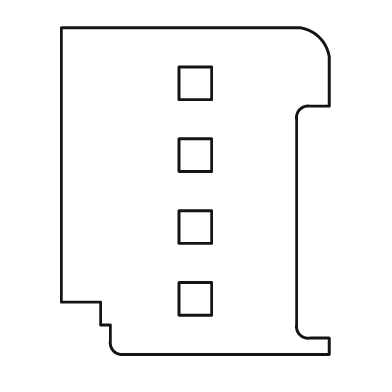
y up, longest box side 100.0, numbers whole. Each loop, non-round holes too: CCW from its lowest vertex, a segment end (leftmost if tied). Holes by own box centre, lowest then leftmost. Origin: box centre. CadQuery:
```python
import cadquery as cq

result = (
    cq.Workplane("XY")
    .moveTo(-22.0, -50.0)
    .lineTo(41.0, -50.0)
    .lineTo(41.0, -45.0)
    .lineTo(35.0, -45.0)
    .threePointArc((32.0, -44.0), (31.0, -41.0))
    .lineTo(31.0, 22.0)
    .threePointArc((32.0, 25.0), (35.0, 26.0))
    .lineTo(41.0, 26.0)
    .lineTo(41.0, 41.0)
    .threePointArc((38.0, 47.0), (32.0, 50.0))
    .lineTo(-41.0, 50.0)
    .lineTo(-41.0, -34.0)
    .lineTo(-29.0, -34.0)
    .lineTo(-29.0, -41.0)
    .lineTo(-26.0, -41.0)
    .lineTo(-26.0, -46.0)
    .threePointArc((-25.0, -49.0), (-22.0, -50.0))
    .close()
    .moveTo(-5.0, -38.0)
    .lineTo(5.0, -38.0)
    .lineTo(5.0, -28.0)
    .lineTo(-5.0, -28.0)
    .close()
    .moveTo(-5.0, -16.0)
    .lineTo(5.0, -16.0)
    .lineTo(5.0, -6.0)
    .lineTo(-5.0, -6.0)
    .close()
    .moveTo(-5.0, 6.0)
    .lineTo(5.0, 6.0)
    .lineTo(5.0, 16.0)
    .lineTo(-5.0, 16.0)
    .close()
    .moveTo(-5.0, 28.0)
    .lineTo(5.0, 28.0)
    .lineTo(5.0, 38.0)
    .lineTo(-5.0, 38.0)
    .close()
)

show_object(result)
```